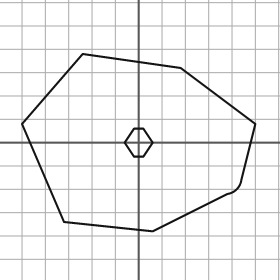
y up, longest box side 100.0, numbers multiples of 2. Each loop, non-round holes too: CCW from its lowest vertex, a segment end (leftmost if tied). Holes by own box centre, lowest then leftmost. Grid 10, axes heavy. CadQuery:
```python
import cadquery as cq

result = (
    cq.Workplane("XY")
    .moveTo(6.0, -38.0)
    .lineTo(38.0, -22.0)
    .threePointArc((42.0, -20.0), (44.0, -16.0))
    .lineTo(50.0, 8.0)
    .lineTo(18.0, 32.0)
    .lineTo(-24.0, 38.0)
    .lineTo(-50.0, 8.0)
    .lineTo(-32.0, -34.0)
    .close()
    .moveTo(-2.0, -6.0)
    .lineTo(2.0, -6.0)
    .lineTo(6.0, 0.0)
    .lineTo(2.0, 6.0)
    .lineTo(-2.0, 6.0)
    .lineTo(-6.0, 0.0)
    .close()
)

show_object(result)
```